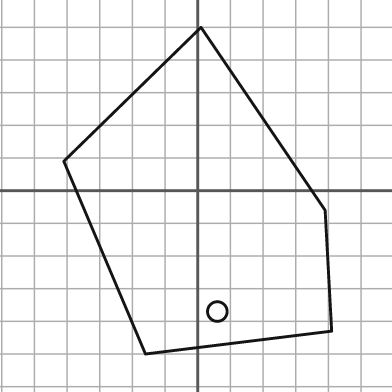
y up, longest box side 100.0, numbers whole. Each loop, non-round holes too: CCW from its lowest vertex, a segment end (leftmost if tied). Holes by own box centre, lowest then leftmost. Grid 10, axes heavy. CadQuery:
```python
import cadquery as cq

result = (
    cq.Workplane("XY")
    .moveTo(-16.0, -50.0)
    .lineTo(41.0, -43.0)
    .lineTo(39.0, -6.0)
    .lineTo(1.0, 50.0)
    .lineTo(-41.0, 9.0)
    .close()
    .moveTo(6.0, -37.0)
    .circle(3.0)
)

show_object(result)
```